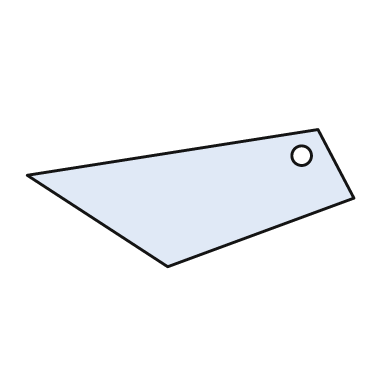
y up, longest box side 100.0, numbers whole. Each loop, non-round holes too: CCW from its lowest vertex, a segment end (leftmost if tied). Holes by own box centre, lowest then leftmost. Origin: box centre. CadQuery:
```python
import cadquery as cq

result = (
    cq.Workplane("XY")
    .moveTo(-7.0, -21.0)
    .lineTo(50.0, 0.0)
    .lineTo(39.0, 21.0)
    .lineTo(-50.0, 7.0)
    .close()
    .moveTo(34.0, 13.0)
    .circle(3.0)
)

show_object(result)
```